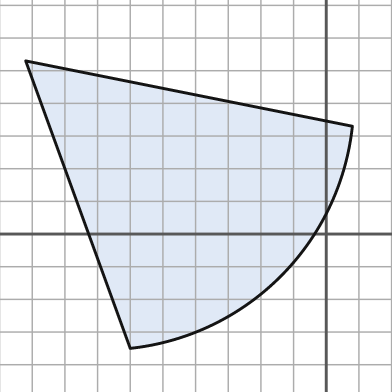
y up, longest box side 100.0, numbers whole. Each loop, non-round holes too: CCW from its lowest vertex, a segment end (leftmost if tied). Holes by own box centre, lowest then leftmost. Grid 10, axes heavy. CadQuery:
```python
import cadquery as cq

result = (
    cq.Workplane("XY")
    .moveTo(-60.0, -35.0)
    .threePointArc((-14.0, -13.0), (8.0, 33.0))
    .lineTo(-92.0, 53.0)
    .close()
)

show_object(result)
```